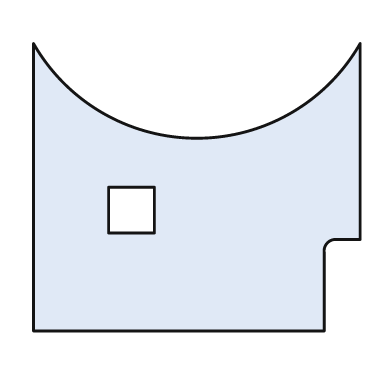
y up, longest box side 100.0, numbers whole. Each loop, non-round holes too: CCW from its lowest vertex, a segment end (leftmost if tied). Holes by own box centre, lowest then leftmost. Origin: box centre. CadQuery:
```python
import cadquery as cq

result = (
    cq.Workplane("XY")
    .moveTo(-50.0, -44.0)
    .lineTo(39.0, -44.0)
    .lineTo(39.0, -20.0)
    .threePointArc((40.0, -17.0), (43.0, -16.0))
    .lineTo(50.0, -16.0)
    .lineTo(50.0, 44.0)
    .threePointArc((0.0, 15.0), (-50.0, 44.0))
    .close()
    .moveTo(-27.0, -14.0)
    .lineTo(-13.0, -14.0)
    .lineTo(-13.0, 0.0)
    .lineTo(-27.0, 0.0)
    .close()
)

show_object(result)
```